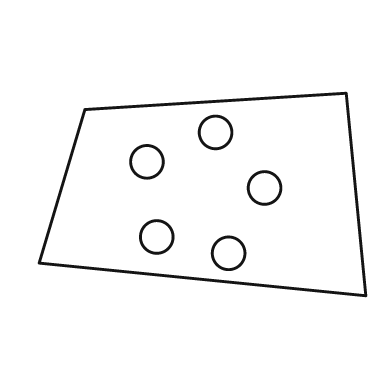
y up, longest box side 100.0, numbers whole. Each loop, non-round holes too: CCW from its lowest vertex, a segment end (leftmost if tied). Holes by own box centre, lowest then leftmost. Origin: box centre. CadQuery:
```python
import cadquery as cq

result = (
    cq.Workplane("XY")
    .moveTo(50.0, -31.0)
    .lineTo(44.0, 31.0)
    .lineTo(-36.0, 26.0)
    .lineTo(-50.0, -21.0)
    .close()
    .moveTo(8.0, -18.0)
    .circle(5.0)
    .moveTo(-14.0, -13.0)
    .circle(5.0)
    .moveTo(19.0, 2.0)
    .circle(5.0)
    .moveTo(-17.0, 10.0)
    .circle(5.0)
    .moveTo(4.0, 19.0)
    .circle(5.0)
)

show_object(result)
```